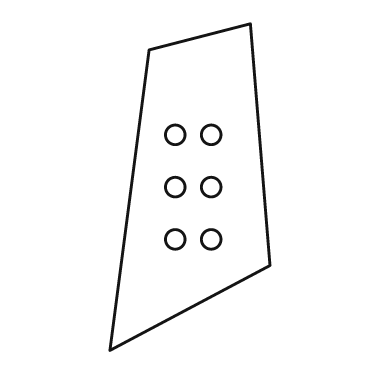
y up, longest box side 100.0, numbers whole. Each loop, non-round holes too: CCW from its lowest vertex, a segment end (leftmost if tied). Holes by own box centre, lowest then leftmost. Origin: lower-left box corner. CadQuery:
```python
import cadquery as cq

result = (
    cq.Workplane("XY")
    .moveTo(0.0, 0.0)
    .lineTo(49.0, 26.0)
    .lineTo(43.0, 100.0)
    .lineTo(12.0, 92.0)
    .close()
    .moveTo(20.0, 34.0)
    .circle(3.0)
    .moveTo(31.0, 34.0)
    .circle(3.0)
    .moveTo(20.0, 50.0)
    .circle(3.0)
    .moveTo(31.0, 50.0)
    .circle(3.0)
    .moveTo(20.0, 66.0)
    .circle(3.0)
    .moveTo(31.0, 66.0)
    .circle(3.0)
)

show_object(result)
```